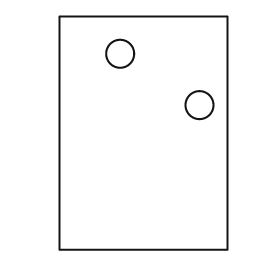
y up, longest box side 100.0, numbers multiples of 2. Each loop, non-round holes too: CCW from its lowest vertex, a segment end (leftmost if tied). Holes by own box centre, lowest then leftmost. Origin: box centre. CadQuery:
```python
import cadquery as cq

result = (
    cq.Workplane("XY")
    .moveTo(-36.0, -50.0)
    .lineTo(36.0, -50.0)
    .lineTo(36.0, 50.0)
    .lineTo(-36.0, 50.0)
    .close()
    .moveTo(24.0, 12.0)
    .circle(6.0)
    .moveTo(-10.0, 34.0)
    .circle(6.0)
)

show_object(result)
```